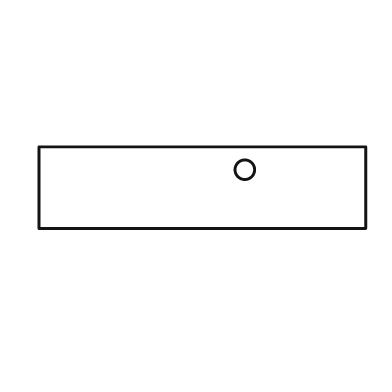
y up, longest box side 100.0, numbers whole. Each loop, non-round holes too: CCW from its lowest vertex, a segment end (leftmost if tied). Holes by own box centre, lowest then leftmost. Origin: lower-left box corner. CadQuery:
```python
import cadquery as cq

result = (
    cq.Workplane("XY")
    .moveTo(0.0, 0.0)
    .lineTo(100.0, 0.0)
    .lineTo(100.0, 25.0)
    .lineTo(0.0, 25.0)
    .close()
    .moveTo(63.0, 18.0)
    .circle(3.0)
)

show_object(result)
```